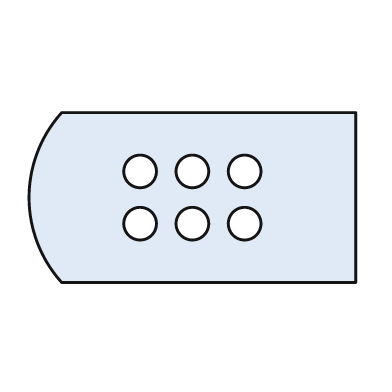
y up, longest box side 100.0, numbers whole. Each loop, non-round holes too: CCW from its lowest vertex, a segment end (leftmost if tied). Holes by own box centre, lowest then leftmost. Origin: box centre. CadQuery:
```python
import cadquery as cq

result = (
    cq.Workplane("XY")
    .moveTo(-40.0, -26.0)
    .lineTo(50.0, -26.0)
    .lineTo(50.0, 26.0)
    .lineTo(-40.0, 26.0)
    .threePointArc((-50.0, 0.0), (-40.0, -26.0))
    .close()
    .moveTo(-16.0, -8.0)
    .circle(5.0)
    .moveTo(0.0, -8.0)
    .circle(5.0)
    .moveTo(16.0, -8.0)
    .circle(5.0)
    .moveTo(-16.0, 8.0)
    .circle(5.0)
    .moveTo(0.0, 8.0)
    .circle(5.0)
    .moveTo(16.0, 8.0)
    .circle(5.0)
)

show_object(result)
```